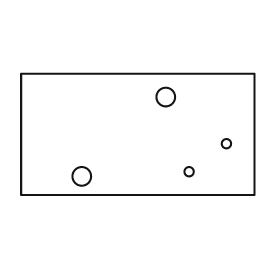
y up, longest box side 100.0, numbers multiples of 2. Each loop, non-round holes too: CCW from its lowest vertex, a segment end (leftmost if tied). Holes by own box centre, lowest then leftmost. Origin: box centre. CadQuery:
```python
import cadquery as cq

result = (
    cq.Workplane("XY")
    .moveTo(-50.0, -26.0)
    .lineTo(50.0, -26.0)
    .lineTo(50.0, 26.0)
    .lineTo(-50.0, 26.0)
    .close()
    .moveTo(-24.0, -18.0)
    .circle(4.0)
    .moveTo(22.0, -16.0)
    .circle(2.0)
    .moveTo(38.0, -4.0)
    .circle(2.0)
    .moveTo(12.0, 16.0)
    .circle(4.0)
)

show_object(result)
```